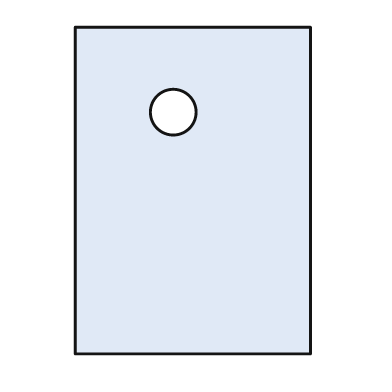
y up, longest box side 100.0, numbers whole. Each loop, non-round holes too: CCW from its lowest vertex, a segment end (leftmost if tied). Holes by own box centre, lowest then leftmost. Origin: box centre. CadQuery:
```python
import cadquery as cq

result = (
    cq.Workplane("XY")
    .moveTo(-36.0, -50.0)
    .lineTo(36.0, -50.0)
    .lineTo(36.0, 50.0)
    .lineTo(-36.0, 50.0)
    .close()
    .moveTo(-6.0, 24.0)
    .circle(7.0)
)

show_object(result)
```